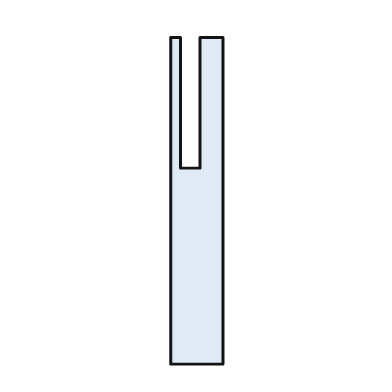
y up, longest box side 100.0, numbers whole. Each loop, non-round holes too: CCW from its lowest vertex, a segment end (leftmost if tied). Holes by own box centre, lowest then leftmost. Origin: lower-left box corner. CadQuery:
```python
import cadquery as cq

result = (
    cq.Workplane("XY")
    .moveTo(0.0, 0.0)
    .lineTo(16.0, 0.0)
    .lineTo(16.0, 100.0)
    .lineTo(9.0, 100.0)
    .lineTo(9.0, 60.0)
    .lineTo(3.0, 60.0)
    .lineTo(3.0, 100.0)
    .lineTo(0.0, 100.0)
    .close()
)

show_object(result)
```